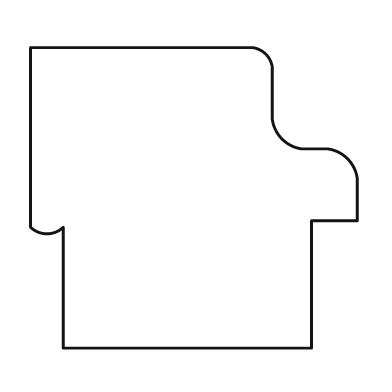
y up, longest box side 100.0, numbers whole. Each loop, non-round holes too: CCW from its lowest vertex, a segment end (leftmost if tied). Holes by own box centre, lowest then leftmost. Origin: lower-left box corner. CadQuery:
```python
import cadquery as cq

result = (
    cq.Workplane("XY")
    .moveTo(10.0, 0.0)
    .lineTo(86.0, 0.0)
    .lineTo(86.0, 39.0)
    .lineTo(100.0, 39.0)
    .lineTo(100.0, 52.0)
    .threePointArc((97.0, 58.0), (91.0, 61.0))
    .lineTo(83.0, 61.0)
    .threePointArc((77.0, 64.0), (74.0, 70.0))
    .lineTo(74.0, 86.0)
    .threePointArc((72.0, 90.0), (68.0, 92.0))
    .lineTo(0.0, 92.0)
    .lineTo(0.0, 37.0)
    .threePointArc((5.0, 35.0), (10.0, 37.0))
    .close()
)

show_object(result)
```